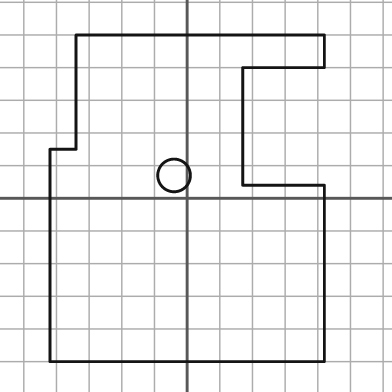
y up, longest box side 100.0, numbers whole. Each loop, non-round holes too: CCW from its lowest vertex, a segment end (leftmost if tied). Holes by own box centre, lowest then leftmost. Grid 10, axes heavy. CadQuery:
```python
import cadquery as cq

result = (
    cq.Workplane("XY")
    .moveTo(-42.0, -50.0)
    .lineTo(42.0, -50.0)
    .lineTo(42.0, 4.0)
    .lineTo(17.0, 4.0)
    .lineTo(17.0, 40.0)
    .lineTo(42.0, 40.0)
    .lineTo(42.0, 50.0)
    .lineTo(-34.0, 50.0)
    .lineTo(-34.0, 15.0)
    .lineTo(-42.0, 15.0)
    .close()
    .moveTo(-4.0, 7.0)
    .circle(5.0)
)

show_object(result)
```